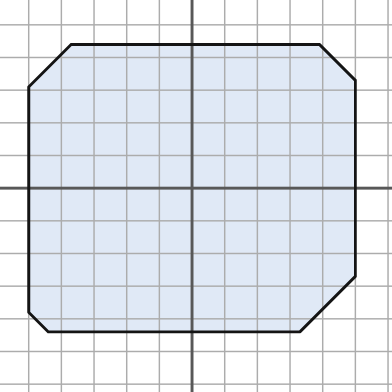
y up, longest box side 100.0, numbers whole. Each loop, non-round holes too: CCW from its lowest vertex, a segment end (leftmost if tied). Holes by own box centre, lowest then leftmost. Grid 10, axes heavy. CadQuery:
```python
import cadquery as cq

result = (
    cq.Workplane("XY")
    .moveTo(-44.0, -44.0)
    .lineTo(33.0, -44.0)
    .lineTo(50.0, -27.0)
    .lineTo(50.0, 33.0)
    .lineTo(39.0, 44.0)
    .lineTo(-37.0, 44.0)
    .lineTo(-50.0, 31.0)
    .lineTo(-50.0, -38.0)
    .close()
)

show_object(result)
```